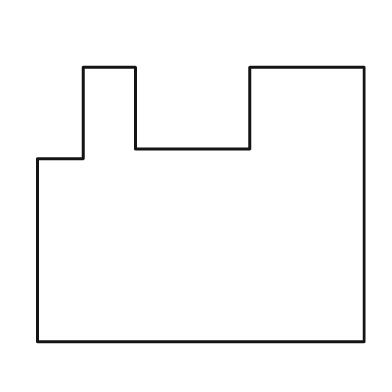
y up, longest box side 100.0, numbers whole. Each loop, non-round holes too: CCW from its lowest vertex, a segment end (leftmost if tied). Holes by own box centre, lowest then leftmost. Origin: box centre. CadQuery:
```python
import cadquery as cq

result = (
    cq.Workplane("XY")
    .moveTo(-50.0, -42.0)
    .lineTo(50.0, -42.0)
    .lineTo(50.0, 42.0)
    .lineTo(15.0, 42.0)
    .lineTo(15.0, 17.0)
    .lineTo(-20.0, 17.0)
    .lineTo(-20.0, 42.0)
    .lineTo(-36.0, 42.0)
    .lineTo(-36.0, 14.0)
    .lineTo(-50.0, 14.0)
    .close()
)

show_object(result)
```